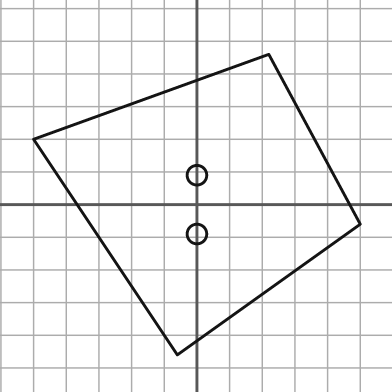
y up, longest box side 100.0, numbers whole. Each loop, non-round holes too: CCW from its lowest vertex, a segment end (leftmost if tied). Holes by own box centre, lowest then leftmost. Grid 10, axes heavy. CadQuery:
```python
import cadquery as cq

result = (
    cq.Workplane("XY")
    .moveTo(-6.0, -46.0)
    .lineTo(50.0, -6.0)
    .lineTo(22.0, 46.0)
    .lineTo(-50.0, 20.0)
    .close()
    .moveTo(0.0, -9.0)
    .circle(3.0)
    .moveTo(0.0, 9.0)
    .circle(3.0)
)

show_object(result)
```